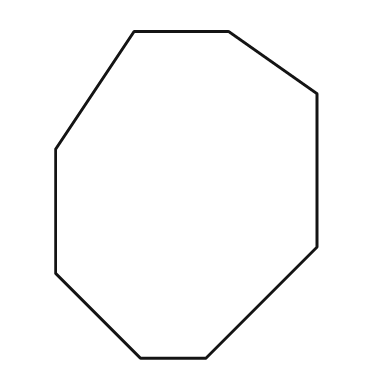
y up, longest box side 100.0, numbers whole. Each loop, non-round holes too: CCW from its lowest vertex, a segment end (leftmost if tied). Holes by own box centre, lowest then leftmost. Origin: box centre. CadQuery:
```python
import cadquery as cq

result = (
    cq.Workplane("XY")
    .moveTo(-14.0, -50.0)
    .lineTo(6.0, -50.0)
    .lineTo(40.0, -16.0)
    .lineTo(40.0, 31.0)
    .lineTo(13.0, 50.0)
    .lineTo(-16.0, 50.0)
    .lineTo(-40.0, 14.0)
    .lineTo(-40.0, -24.0)
    .close()
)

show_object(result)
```